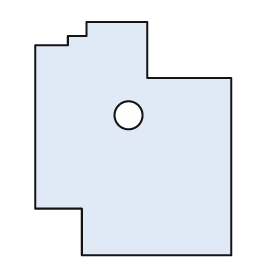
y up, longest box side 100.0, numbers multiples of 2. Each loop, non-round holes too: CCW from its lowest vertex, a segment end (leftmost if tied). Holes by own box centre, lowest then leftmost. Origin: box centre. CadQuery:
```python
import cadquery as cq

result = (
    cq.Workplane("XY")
    .moveTo(-22.0, -50.0)
    .lineTo(42.0, -50.0)
    .lineTo(42.0, 26.0)
    .lineTo(6.0, 26.0)
    .lineTo(6.0, 50.0)
    .lineTo(-20.0, 50.0)
    .lineTo(-20.0, 44.0)
    .lineTo(-28.0, 44.0)
    .lineTo(-28.0, 40.0)
    .lineTo(-42.0, 40.0)
    .lineTo(-42.0, -30.0)
    .lineTo(-22.0, -30.0)
    .close()
    .moveTo(-2.0, 10.0)
    .circle(6.0)
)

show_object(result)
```